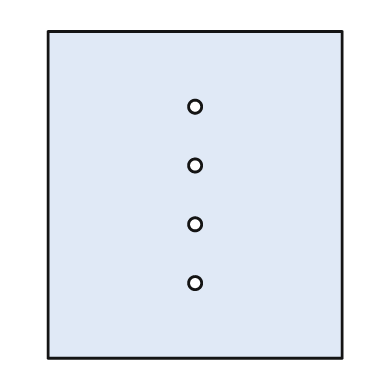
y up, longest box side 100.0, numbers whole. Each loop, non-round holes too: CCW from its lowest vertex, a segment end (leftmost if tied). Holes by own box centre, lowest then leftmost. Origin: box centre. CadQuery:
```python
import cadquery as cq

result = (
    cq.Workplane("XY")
    .moveTo(-45.0, -50.0)
    .lineTo(45.0, -50.0)
    .lineTo(45.0, 50.0)
    .lineTo(-45.0, 50.0)
    .close()
    .moveTo(0.0, -27.0)
    .circle(2.0)
    .moveTo(0.0, -9.0)
    .circle(2.0)
    .moveTo(0.0, 9.0)
    .circle(2.0)
    .moveTo(0.0, 27.0)
    .circle(2.0)
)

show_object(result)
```